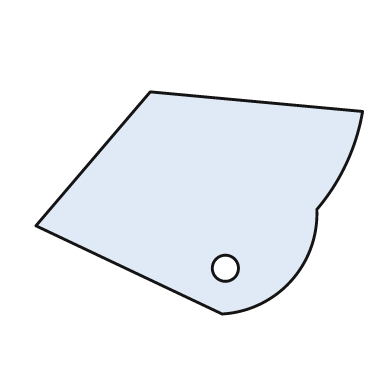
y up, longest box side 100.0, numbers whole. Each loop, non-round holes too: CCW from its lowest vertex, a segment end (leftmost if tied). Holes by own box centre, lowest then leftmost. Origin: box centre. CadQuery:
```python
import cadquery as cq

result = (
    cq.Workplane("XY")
    .moveTo(7.0, -34.0)
    .threePointArc((28.0, -24.0), (36.0, -2.0))
    .threePointArc((45.0, 12.0), (50.0, 28.0))
    .lineTo(-15.0, 34.0)
    .lineTo(-50.0, -7.0)
    .close()
    .moveTo(8.0, -20.0)
    .circle(4.0)
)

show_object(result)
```